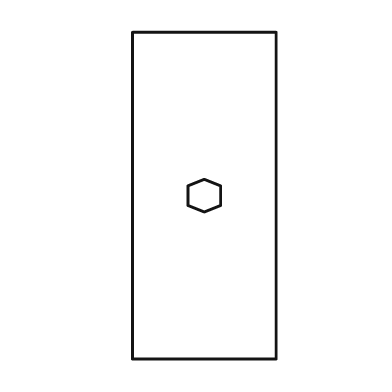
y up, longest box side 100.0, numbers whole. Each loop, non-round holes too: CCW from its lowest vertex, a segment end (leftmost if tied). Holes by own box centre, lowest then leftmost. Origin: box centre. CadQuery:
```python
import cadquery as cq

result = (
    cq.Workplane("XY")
    .moveTo(-22.0, -50.0)
    .lineTo(22.0, -50.0)
    .lineTo(22.0, 50.0)
    .lineTo(-22.0, 50.0)
    .close()
    .moveTo(0.0, -5.0)
    .lineTo(5.0, -3.0)
    .lineTo(5.0, 3.0)
    .lineTo(0.0, 5.0)
    .lineTo(-5.0, 3.0)
    .lineTo(-5.0, -3.0)
    .close()
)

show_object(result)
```